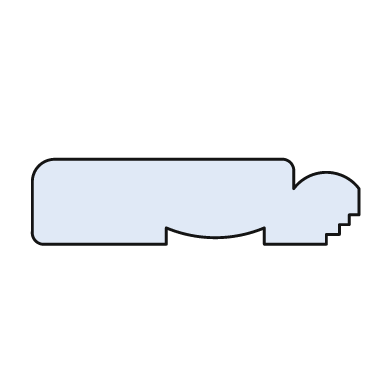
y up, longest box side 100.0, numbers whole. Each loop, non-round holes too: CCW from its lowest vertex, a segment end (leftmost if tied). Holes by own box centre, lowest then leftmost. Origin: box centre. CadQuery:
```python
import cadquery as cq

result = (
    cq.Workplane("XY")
    .moveTo(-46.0, -13.0)
    .lineTo(-9.0, -13.0)
    .lineTo(-9.0, -8.0)
    .threePointArc((6.0, -11.0), (21.0, -8.0))
    .lineTo(21.0, -13.0)
    .lineTo(40.0, -13.0)
    .lineTo(40.0, -10.0)
    .lineTo(44.0, -10.0)
    .lineTo(44.0, -7.0)
    .lineTo(47.0, -7.0)
    .lineTo(47.0, -4.0)
    .lineTo(50.0, -4.0)
    .lineTo(50.0, 4.0)
    .threePointArc((40.0, 9.0), (30.0, 4.0))
    .lineTo(30.0, 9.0)
    .threePointArc((29.0, 12.0), (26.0, 13.0))
    .lineTo(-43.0, 13.0)
    .threePointArc((-48.0, 11.0), (-50.0, 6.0))
    .lineTo(-50.0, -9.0)
    .threePointArc((-49.0, -12.0), (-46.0, -13.0))
    .close()
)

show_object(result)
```